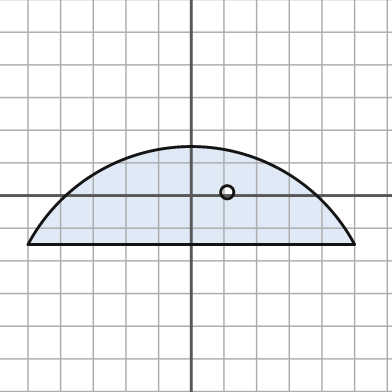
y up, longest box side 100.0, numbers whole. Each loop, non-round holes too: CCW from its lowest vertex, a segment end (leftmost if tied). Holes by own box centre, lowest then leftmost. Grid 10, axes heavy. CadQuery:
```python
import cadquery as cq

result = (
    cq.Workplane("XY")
    .moveTo(-50.0, -15.0)
    .lineTo(50.0, -15.0)
    .threePointArc((0.0, 15.0), (-50.0, -15.0))
    .close()
    .moveTo(11.0, 1.0)
    .circle(2.0)
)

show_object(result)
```